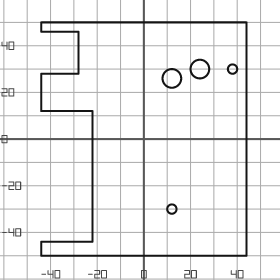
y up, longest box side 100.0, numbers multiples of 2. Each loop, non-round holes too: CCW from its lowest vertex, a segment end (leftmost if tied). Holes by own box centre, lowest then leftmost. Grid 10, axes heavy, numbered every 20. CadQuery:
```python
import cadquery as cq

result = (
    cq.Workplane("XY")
    .moveTo(-44.0, -50.0)
    .lineTo(44.0, -50.0)
    .lineTo(44.0, 50.0)
    .lineTo(-44.0, 50.0)
    .lineTo(-44.0, 46.0)
    .lineTo(-28.0, 46.0)
    .lineTo(-28.0, 28.0)
    .lineTo(-44.0, 28.0)
    .lineTo(-44.0, 12.0)
    .lineTo(-22.0, 12.0)
    .lineTo(-22.0, -44.0)
    .lineTo(-44.0, -44.0)
    .close()
    .moveTo(12.0, -30.0)
    .circle(2.0)
    .moveTo(12.0, 26.0)
    .circle(4.0)
    .moveTo(24.0, 30.0)
    .circle(4.0)
    .moveTo(38.0, 30.0)
    .circle(2.0)
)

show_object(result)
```